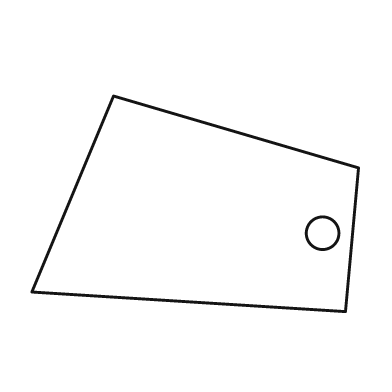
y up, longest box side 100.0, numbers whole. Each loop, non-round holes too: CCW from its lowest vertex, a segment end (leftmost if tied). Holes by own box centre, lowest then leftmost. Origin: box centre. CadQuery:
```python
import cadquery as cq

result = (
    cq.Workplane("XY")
    .moveTo(46.0, -33.0)
    .lineTo(50.0, 11.0)
    .lineTo(-25.0, 33.0)
    .lineTo(-50.0, -27.0)
    .close()
    .moveTo(39.0, -9.0)
    .circle(5.0)
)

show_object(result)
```